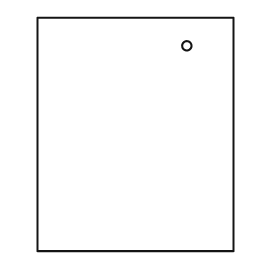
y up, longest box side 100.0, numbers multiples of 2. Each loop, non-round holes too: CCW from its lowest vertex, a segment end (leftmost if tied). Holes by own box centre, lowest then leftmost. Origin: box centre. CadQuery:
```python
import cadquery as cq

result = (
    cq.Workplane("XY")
    .moveTo(-42.0, -50.0)
    .lineTo(42.0, -50.0)
    .lineTo(42.0, 50.0)
    .lineTo(-42.0, 50.0)
    .close()
    .moveTo(22.0, 38.0)
    .circle(2.0)
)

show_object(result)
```